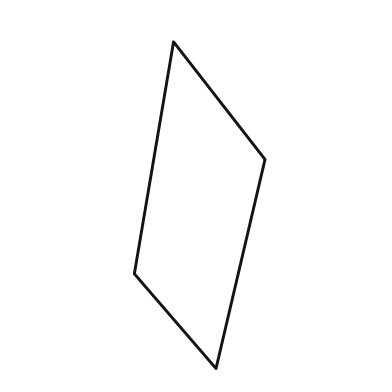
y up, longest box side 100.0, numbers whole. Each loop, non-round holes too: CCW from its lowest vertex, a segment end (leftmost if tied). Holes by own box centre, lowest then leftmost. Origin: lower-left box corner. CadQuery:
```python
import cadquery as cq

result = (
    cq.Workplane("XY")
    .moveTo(25.0, 0.0)
    .lineTo(40.0, 64.0)
    .lineTo(12.0, 100.0)
    .lineTo(0.0, 29.0)
    .close()
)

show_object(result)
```